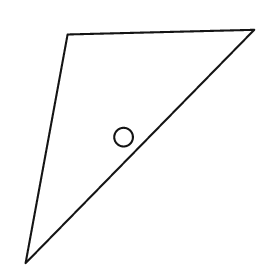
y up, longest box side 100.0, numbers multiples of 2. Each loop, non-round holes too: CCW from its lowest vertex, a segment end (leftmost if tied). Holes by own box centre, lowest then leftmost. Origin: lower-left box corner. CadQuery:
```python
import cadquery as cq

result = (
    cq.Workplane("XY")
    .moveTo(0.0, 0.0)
    .lineTo(98.0, 100.0)
    .lineTo(18.0, 98.0)
    .close()
    .moveTo(42.0, 54.0)
    .circle(4.0)
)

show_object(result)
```